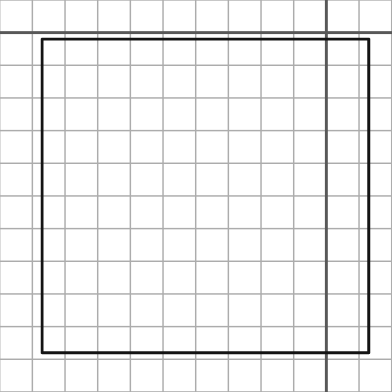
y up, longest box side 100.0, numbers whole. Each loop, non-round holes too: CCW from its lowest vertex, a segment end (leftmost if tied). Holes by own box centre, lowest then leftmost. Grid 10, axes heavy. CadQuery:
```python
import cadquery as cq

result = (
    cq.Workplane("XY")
    .moveTo(-87.0, -98.0)
    .lineTo(13.0, -98.0)
    .lineTo(13.0, -2.0)
    .lineTo(-87.0, -2.0)
    .close()
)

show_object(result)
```